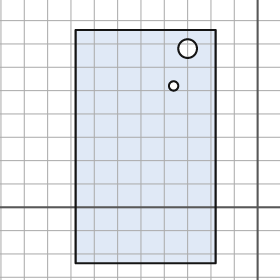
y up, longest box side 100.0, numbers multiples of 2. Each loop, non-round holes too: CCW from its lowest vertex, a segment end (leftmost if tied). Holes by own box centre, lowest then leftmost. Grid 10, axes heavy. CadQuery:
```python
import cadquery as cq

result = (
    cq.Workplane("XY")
    .moveTo(-78.0, -24.0)
    .lineTo(-18.0, -24.0)
    .lineTo(-18.0, 76.0)
    .lineTo(-78.0, 76.0)
    .close()
    .moveTo(-36.0, 52.0)
    .circle(2.0)
    .moveTo(-30.0, 68.0)
    .circle(4.0)
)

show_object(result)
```